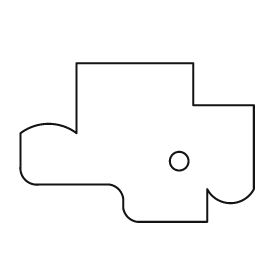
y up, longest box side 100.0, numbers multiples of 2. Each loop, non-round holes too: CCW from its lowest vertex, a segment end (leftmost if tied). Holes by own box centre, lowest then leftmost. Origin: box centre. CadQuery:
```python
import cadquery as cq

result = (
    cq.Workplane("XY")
    .moveTo(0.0, -34.0)
    .lineTo(30.0, -34.0)
    .lineTo(30.0, -20.0)
    .threePointArc((40.0, -26.0), (50.0, -20.0))
    .lineTo(50.0, 16.0)
    .lineTo(24.0, 16.0)
    .lineTo(24.0, 34.0)
    .lineTo(-26.0, 34.0)
    .lineTo(-26.0, 4.0)
    .threePointArc((-38.0, 8.0), (-50.0, 4.0))
    .lineTo(-50.0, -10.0)
    .threePointArc((-48.0, -16.0), (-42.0, -18.0))
    .lineTo(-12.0, -18.0)
    .threePointArc((-8.0, -20.0), (-6.0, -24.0))
    .lineTo(-6.0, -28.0)
    .threePointArc((-4.0, -32.0), (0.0, -34.0))
    .close()
    .moveTo(18.0, -8.0)
    .circle(4.0)
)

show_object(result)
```